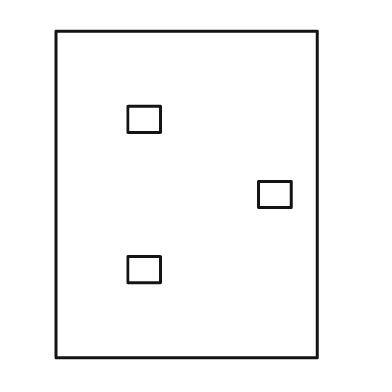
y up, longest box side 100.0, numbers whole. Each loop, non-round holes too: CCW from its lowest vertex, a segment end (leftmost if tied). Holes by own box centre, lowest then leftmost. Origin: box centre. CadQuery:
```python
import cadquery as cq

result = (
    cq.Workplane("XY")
    .moveTo(-40.0, -50.0)
    .lineTo(40.0, -50.0)
    .lineTo(40.0, 50.0)
    .lineTo(-40.0, 50.0)
    .close()
    .moveTo(-18.0, -27.0)
    .lineTo(-8.0, -27.0)
    .lineTo(-8.0, -19.0)
    .lineTo(-18.0, -19.0)
    .close()
    .moveTo(22.0, -4.0)
    .lineTo(32.0, -4.0)
    .lineTo(32.0, 4.0)
    .lineTo(22.0, 4.0)
    .close()
    .moveTo(-18.0, 19.0)
    .lineTo(-8.0, 19.0)
    .lineTo(-8.0, 27.0)
    .lineTo(-18.0, 27.0)
    .close()
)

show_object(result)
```